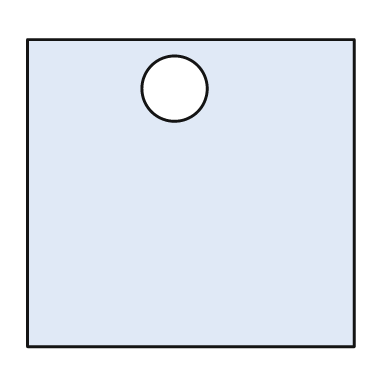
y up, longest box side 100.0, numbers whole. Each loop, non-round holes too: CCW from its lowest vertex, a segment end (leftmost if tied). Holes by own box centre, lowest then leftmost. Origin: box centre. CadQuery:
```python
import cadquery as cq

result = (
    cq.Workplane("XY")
    .moveTo(-50.0, -47.0)
    .lineTo(50.0, -47.0)
    .lineTo(50.0, 47.0)
    .lineTo(-50.0, 47.0)
    .close()
    .moveTo(-5.0, 32.0)
    .circle(10.0)
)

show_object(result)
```